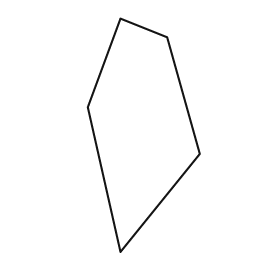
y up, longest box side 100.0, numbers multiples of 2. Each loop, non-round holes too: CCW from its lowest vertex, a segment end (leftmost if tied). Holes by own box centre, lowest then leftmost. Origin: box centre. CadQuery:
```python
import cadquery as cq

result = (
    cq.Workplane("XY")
    .moveTo(-10.0, -50.0)
    .lineTo(24.0, -8.0)
    .lineTo(10.0, 42.0)
    .lineTo(-10.0, 50.0)
    .lineTo(-24.0, 12.0)
    .close()
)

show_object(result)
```